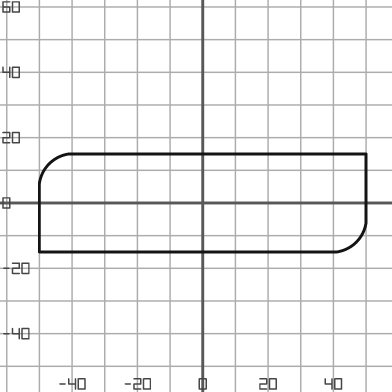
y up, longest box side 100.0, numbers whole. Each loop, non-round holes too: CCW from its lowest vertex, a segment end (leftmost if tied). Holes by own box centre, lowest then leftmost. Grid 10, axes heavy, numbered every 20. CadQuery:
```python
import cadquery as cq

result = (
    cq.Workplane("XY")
    .moveTo(-50.0, -15.0)
    .lineTo(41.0, -15.0)
    .threePointArc((47.0, -12.0), (50.0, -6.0))
    .lineTo(50.0, 15.0)
    .lineTo(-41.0, 15.0)
    .threePointArc((-47.0, 12.0), (-50.0, 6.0))
    .close()
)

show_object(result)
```